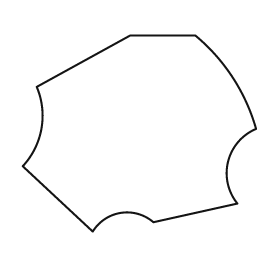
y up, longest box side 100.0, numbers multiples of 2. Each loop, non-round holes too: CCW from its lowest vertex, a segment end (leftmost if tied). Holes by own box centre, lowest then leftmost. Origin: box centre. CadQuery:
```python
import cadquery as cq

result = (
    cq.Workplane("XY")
    .moveTo(-20.0, -42.0)
    .threePointArc((-8.0, -34.0), (6.0, -38.0))
    .lineTo(42.0, -30.0)
    .threePointArc((38.0, -12.0), (50.0, 2.0))
    .threePointArc((40.0, 24.0), (24.0, 42.0))
    .lineTo(-4.0, 42.0)
    .lineTo(-44.0, 20.0)
    .threePointArc((-42.0, 2.0), (-50.0, -14.0))
    .close()
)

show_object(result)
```